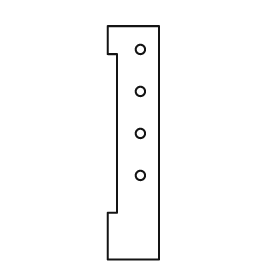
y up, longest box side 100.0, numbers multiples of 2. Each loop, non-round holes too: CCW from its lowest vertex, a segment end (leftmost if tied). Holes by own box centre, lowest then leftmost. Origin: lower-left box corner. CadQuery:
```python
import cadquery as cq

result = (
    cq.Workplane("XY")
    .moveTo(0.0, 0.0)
    .lineTo(22.0, 0.0)
    .lineTo(22.0, 100.0)
    .lineTo(0.0, 100.0)
    .lineTo(0.0, 88.0)
    .lineTo(4.0, 88.0)
    .lineTo(4.0, 20.0)
    .lineTo(0.0, 20.0)
    .close()
    .moveTo(14.0, 36.0)
    .circle(2.0)
    .moveTo(14.0, 54.0)
    .circle(2.0)
    .moveTo(14.0, 72.0)
    .circle(2.0)
    .moveTo(14.0, 90.0)
    .circle(2.0)
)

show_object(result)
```